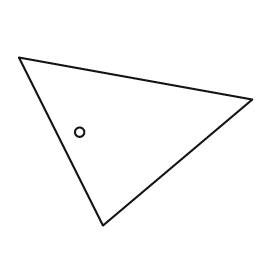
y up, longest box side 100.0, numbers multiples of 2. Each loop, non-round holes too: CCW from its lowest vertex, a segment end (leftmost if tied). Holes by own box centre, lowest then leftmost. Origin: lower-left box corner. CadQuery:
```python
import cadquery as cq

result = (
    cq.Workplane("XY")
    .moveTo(36.0, 0.0)
    .lineTo(100.0, 54.0)
    .lineTo(0.0, 72.0)
    .close()
    .moveTo(26.0, 40.0)
    .circle(2.0)
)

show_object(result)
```